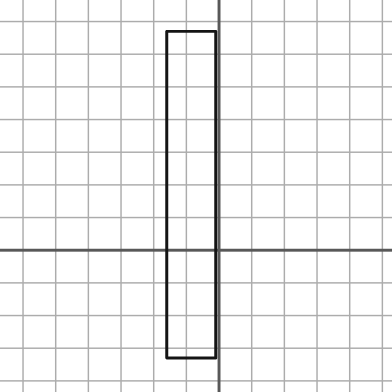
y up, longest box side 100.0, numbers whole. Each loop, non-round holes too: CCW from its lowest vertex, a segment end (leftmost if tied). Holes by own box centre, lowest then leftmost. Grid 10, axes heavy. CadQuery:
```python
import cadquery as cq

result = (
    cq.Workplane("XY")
    .moveTo(-16.0, -33.0)
    .lineTo(-1.0, -33.0)
    .lineTo(-1.0, 67.0)
    .lineTo(-16.0, 67.0)
    .close()
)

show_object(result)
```